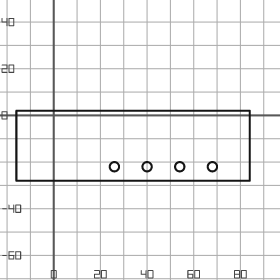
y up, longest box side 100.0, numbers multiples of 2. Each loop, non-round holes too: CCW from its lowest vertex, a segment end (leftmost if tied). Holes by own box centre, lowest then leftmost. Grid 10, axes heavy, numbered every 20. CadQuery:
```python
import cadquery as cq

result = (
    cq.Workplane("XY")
    .moveTo(-16.0, -28.0)
    .lineTo(84.0, -28.0)
    .lineTo(84.0, 2.0)
    .lineTo(-16.0, 2.0)
    .close()
    .moveTo(26.0, -22.0)
    .circle(2.0)
    .moveTo(40.0, -22.0)
    .circle(2.0)
    .moveTo(54.0, -22.0)
    .circle(2.0)
    .moveTo(68.0, -22.0)
    .circle(2.0)
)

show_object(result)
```